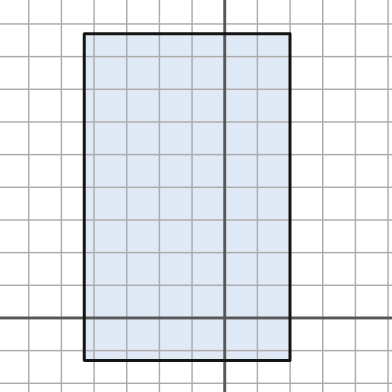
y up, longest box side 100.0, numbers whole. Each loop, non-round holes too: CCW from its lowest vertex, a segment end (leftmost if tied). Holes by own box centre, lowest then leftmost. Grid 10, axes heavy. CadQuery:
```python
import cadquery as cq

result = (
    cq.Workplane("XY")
    .moveTo(-43.0, -13.0)
    .lineTo(20.0, -13.0)
    .lineTo(20.0, 87.0)
    .lineTo(-43.0, 87.0)
    .close()
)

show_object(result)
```